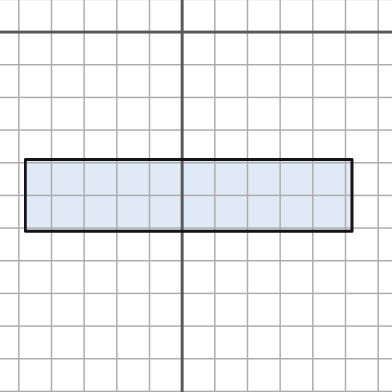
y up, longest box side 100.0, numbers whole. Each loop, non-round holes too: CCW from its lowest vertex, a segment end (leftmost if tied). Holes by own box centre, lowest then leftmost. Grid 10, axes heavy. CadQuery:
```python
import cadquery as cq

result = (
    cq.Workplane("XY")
    .moveTo(-48.0, -61.0)
    .lineTo(52.0, -61.0)
    .lineTo(52.0, -39.0)
    .lineTo(-48.0, -39.0)
    .close()
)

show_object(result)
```